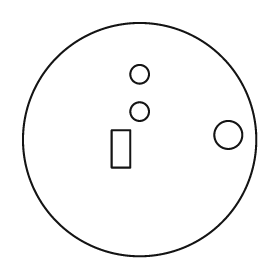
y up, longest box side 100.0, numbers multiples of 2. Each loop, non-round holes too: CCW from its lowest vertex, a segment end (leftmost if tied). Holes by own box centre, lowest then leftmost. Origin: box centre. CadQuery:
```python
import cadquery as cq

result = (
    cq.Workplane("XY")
    .moveTo(0.0, 0.0)
    .circle(50.0)
    .moveTo(-12.0, -12.0)
    .lineTo(-4.0, -12.0)
    .lineTo(-4.0, 4.0)
    .lineTo(-12.0, 4.0)
    .close()
    .moveTo(38.0, 2.0)
    .circle(6.0)
    .moveTo(0.0, 12.0)
    .circle(4.0)
    .moveTo(0.0, 28.0)
    .circle(4.0)
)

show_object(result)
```